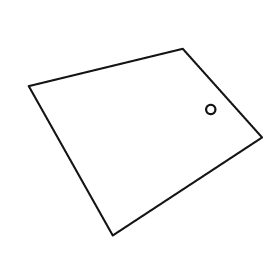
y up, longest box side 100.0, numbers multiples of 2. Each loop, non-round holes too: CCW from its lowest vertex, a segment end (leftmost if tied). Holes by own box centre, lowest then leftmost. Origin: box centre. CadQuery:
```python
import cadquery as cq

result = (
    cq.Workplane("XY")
    .moveTo(-14.0, -40.0)
    .lineTo(50.0, 2.0)
    .lineTo(16.0, 40.0)
    .lineTo(-50.0, 24.0)
    .close()
    .moveTo(28.0, 14.0)
    .circle(2.0)
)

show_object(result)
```